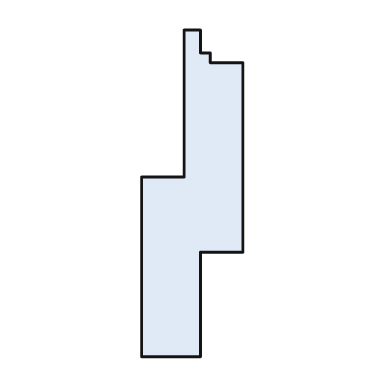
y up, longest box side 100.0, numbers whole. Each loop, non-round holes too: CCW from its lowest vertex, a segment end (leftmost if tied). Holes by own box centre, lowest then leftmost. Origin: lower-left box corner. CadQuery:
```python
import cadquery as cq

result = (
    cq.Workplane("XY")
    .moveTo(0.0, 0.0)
    .lineTo(18.0, 0.0)
    .lineTo(18.0, 32.0)
    .lineTo(31.0, 32.0)
    .lineTo(31.0, 90.0)
    .lineTo(21.0, 90.0)
    .lineTo(21.0, 93.0)
    .lineTo(18.0, 93.0)
    .lineTo(18.0, 100.0)
    .lineTo(13.0, 100.0)
    .lineTo(13.0, 55.0)
    .lineTo(0.0, 55.0)
    .close()
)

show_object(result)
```